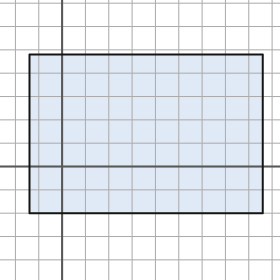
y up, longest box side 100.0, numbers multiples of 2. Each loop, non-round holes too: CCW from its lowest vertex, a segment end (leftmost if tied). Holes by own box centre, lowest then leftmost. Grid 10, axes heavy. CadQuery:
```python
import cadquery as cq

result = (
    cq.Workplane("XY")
    .moveTo(-14.0, -20.0)
    .lineTo(86.0, -20.0)
    .lineTo(86.0, 48.0)
    .lineTo(-14.0, 48.0)
    .close()
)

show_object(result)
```